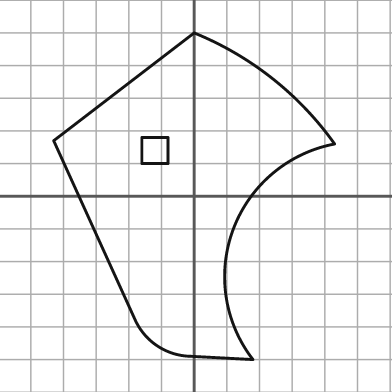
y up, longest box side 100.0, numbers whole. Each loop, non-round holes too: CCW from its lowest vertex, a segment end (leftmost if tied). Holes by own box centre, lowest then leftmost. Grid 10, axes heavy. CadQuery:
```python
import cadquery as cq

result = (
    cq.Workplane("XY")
    .moveTo(18.0, -50.0)
    .threePointArc((12.0, -10.0), (43.0, 16.0))
    .threePointArc((24.0, 36.0), (0.0, 50.0))
    .lineTo(-43.0, 17.0)
    .lineTo(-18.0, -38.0)
    .threePointArc((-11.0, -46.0), (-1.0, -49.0))
    .close()
    .moveTo(-16.0, 10.0)
    .lineTo(-8.0, 10.0)
    .lineTo(-8.0, 18.0)
    .lineTo(-16.0, 18.0)
    .close()
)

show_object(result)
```